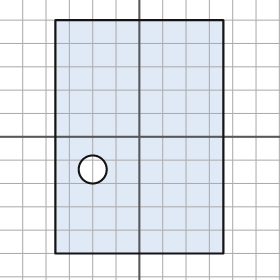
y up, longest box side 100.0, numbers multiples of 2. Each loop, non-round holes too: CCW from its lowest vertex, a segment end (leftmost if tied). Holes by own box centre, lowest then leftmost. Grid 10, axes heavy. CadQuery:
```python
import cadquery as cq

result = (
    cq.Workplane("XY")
    .moveTo(-36.0, -50.0)
    .lineTo(36.0, -50.0)
    .lineTo(36.0, 50.0)
    .lineTo(-36.0, 50.0)
    .close()
    .moveTo(-20.0, -14.0)
    .circle(6.0)
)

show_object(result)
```